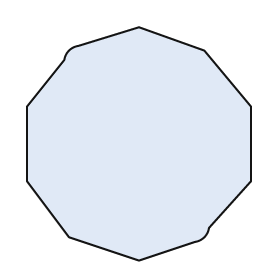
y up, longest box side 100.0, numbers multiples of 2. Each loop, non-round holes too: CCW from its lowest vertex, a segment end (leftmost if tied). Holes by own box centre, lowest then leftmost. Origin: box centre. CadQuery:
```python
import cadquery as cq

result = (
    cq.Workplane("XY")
    .moveTo(0.0, -50.0)
    .lineTo(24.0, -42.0)
    .threePointArc((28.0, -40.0), (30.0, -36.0))
    .lineTo(48.0, -16.0)
    .lineTo(48.0, 16.0)
    .lineTo(28.0, 40.0)
    .lineTo(0.0, 50.0)
    .lineTo(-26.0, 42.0)
    .threePointArc((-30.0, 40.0), (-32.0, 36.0))
    .lineTo(-48.0, 16.0)
    .lineTo(-48.0, -16.0)
    .lineTo(-30.0, -40.0)
    .close()
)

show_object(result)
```